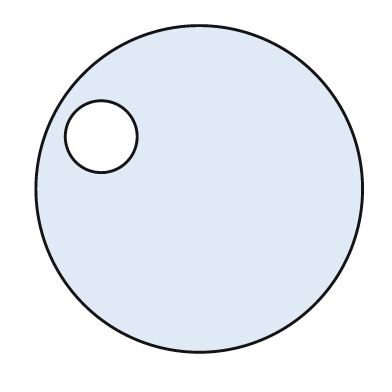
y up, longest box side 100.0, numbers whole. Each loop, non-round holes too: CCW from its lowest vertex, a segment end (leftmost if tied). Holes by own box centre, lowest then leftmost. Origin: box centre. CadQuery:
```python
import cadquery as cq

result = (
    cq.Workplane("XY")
    .moveTo(0.0, 0.0)
    .circle(50.0)
    .moveTo(-30.0, 16.0)
    .circle(11.0)
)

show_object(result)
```